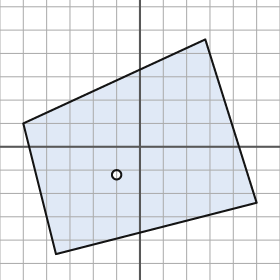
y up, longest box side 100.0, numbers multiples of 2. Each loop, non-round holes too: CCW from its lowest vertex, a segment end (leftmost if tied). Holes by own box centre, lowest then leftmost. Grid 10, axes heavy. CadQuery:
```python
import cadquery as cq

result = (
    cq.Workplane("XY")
    .moveTo(-36.0, -46.0)
    .lineTo(50.0, -24.0)
    .lineTo(28.0, 46.0)
    .lineTo(-50.0, 10.0)
    .close()
    .moveTo(-10.0, -12.0)
    .circle(2.0)
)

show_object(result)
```